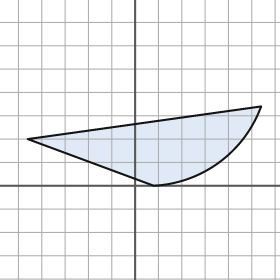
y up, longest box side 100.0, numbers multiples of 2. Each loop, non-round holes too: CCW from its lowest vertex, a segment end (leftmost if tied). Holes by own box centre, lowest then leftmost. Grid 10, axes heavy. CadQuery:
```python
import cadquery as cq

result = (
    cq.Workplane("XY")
    .moveTo(8.0, 0.0)
    .threePointArc((36.0, 10.0), (54.0, 34.0))
    .lineTo(-46.0, 20.0)
    .close()
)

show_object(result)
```